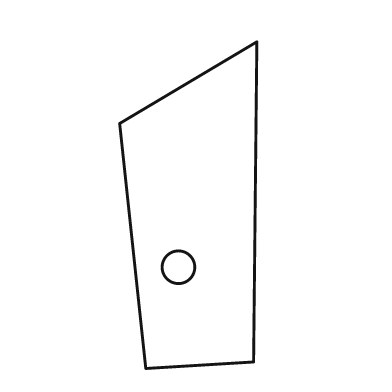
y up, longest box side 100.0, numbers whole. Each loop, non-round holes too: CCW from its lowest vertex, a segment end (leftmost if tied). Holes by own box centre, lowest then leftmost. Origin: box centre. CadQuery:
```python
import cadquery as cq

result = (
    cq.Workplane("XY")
    .moveTo(-13.0, -50.0)
    .lineTo(20.0, -48.0)
    .lineTo(21.0, 50.0)
    .lineTo(-21.0, 25.0)
    .close()
    .moveTo(-3.0, -19.0)
    .circle(5.0)
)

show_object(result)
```